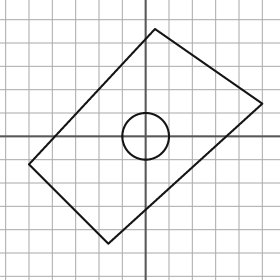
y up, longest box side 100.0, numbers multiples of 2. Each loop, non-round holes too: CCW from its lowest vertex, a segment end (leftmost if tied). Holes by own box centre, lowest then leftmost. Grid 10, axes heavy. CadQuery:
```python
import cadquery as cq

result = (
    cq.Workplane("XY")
    .moveTo(-16.0, -46.0)
    .lineTo(50.0, 14.0)
    .lineTo(4.0, 46.0)
    .lineTo(-50.0, -12.0)
    .close()
    .moveTo(0.0, 0.0)
    .circle(10.0)
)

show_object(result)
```